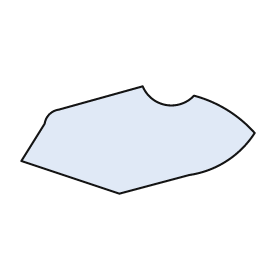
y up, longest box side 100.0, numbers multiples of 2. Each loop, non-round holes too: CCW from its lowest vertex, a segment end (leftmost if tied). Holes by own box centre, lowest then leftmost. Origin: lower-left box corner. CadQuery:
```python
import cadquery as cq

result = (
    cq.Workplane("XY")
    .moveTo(42.0, 0.0)
    .lineTo(72.0, 8.0)
    .threePointArc((88.0, 14.0), (100.0, 26.0))
    .threePointArc((88.0, 36.0), (74.0, 42.0))
    .threePointArc((62.0, 38.0), (52.0, 46.0))
    .lineTo(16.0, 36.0)
    .threePointArc((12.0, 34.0), (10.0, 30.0))
    .lineTo(0.0, 14.0)
    .close()
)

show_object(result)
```